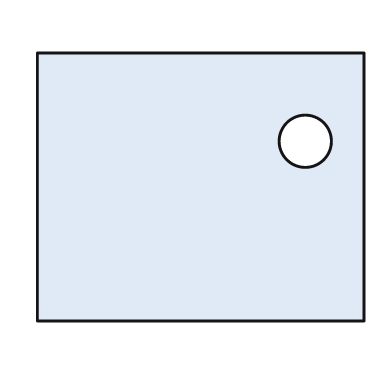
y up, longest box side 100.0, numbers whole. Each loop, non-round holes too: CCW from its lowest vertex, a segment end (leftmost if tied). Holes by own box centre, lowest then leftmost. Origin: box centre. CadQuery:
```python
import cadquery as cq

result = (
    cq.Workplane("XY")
    .moveTo(-50.0, -41.0)
    .lineTo(50.0, -41.0)
    .lineTo(50.0, 41.0)
    .lineTo(-50.0, 41.0)
    .close()
    .moveTo(32.0, 14.0)
    .circle(8.0)
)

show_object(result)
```